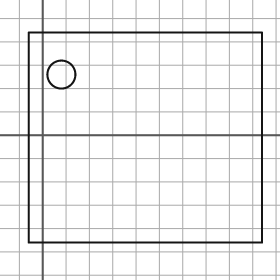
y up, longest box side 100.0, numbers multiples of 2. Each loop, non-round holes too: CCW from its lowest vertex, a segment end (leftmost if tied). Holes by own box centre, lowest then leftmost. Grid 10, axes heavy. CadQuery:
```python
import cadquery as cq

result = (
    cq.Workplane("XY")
    .moveTo(-6.0, -46.0)
    .lineTo(94.0, -46.0)
    .lineTo(94.0, 44.0)
    .lineTo(-6.0, 44.0)
    .close()
    .moveTo(8.0, 26.0)
    .circle(6.0)
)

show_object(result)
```